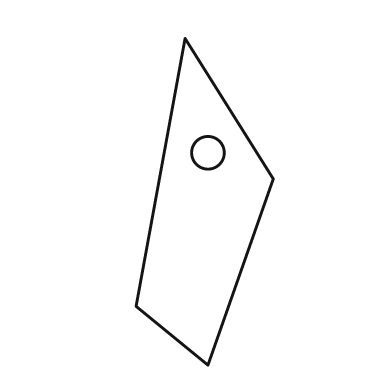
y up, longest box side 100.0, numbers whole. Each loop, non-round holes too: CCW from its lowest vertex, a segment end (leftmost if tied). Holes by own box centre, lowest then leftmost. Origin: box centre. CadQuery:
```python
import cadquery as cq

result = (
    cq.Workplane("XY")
    .moveTo(1.0, -50.0)
    .lineTo(21.0, 7.0)
    .lineTo(-6.0, 50.0)
    .lineTo(-21.0, -32.0)
    .close()
    .moveTo(1.0, 15.0)
    .circle(5.0)
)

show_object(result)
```